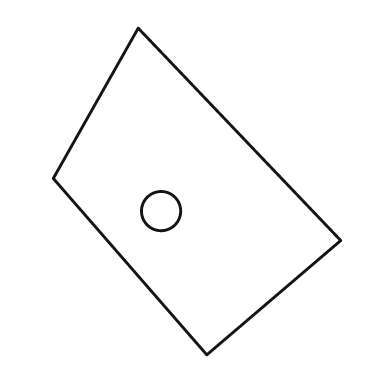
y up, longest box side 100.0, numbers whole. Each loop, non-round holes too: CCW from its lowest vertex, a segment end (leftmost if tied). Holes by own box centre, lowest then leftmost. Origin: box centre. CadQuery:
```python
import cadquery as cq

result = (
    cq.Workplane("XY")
    .moveTo(3.0, -50.0)
    .lineTo(44.0, -15.0)
    .lineTo(-18.0, 50.0)
    .lineTo(-44.0, 4.0)
    .close()
    .moveTo(-11.0, -6.0)
    .circle(6.0)
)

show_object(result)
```